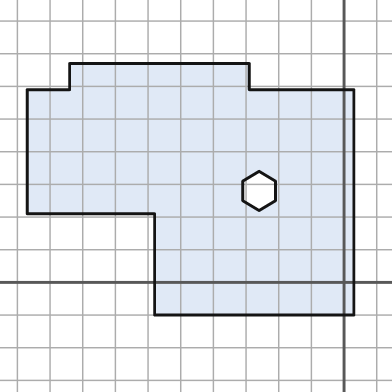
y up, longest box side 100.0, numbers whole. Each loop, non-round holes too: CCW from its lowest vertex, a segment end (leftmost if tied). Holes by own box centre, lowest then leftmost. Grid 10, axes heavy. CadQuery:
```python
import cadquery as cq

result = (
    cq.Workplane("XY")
    .moveTo(-58.0, -10.0)
    .lineTo(3.0, -10.0)
    .lineTo(3.0, 59.0)
    .lineTo(-29.0, 59.0)
    .lineTo(-29.0, 67.0)
    .lineTo(-84.0, 67.0)
    .lineTo(-84.0, 59.0)
    .lineTo(-97.0, 59.0)
    .lineTo(-97.0, 21.0)
    .lineTo(-58.0, 21.0)
    .close()
    .moveTo(-26.0, 22.0)
    .lineTo(-21.0, 25.0)
    .lineTo(-21.0, 31.0)
    .lineTo(-26.0, 34.0)
    .lineTo(-31.0, 31.0)
    .lineTo(-31.0, 25.0)
    .close()
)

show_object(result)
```